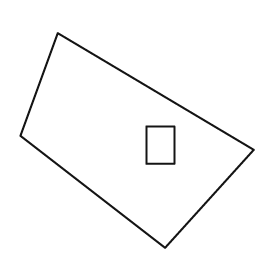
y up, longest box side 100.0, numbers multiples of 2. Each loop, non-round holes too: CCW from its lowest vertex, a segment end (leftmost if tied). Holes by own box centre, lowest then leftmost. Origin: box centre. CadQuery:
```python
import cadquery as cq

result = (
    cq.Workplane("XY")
    .moveTo(12.0, -46.0)
    .lineTo(50.0, -4.0)
    .lineTo(-34.0, 46.0)
    .lineTo(-50.0, 2.0)
    .close()
    .moveTo(4.0, -10.0)
    .lineTo(16.0, -10.0)
    .lineTo(16.0, 6.0)
    .lineTo(4.0, 6.0)
    .close()
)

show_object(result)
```